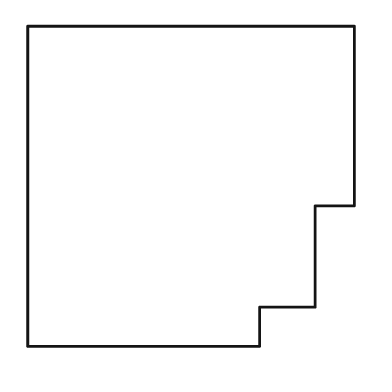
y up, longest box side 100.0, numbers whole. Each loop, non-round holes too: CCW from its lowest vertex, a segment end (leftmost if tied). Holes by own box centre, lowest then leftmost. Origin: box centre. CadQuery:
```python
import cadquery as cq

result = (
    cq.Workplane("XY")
    .moveTo(-50.0, -49.0)
    .lineTo(21.0, -49.0)
    .lineTo(21.0, -37.0)
    .lineTo(38.0, -37.0)
    .lineTo(38.0, -6.0)
    .lineTo(50.0, -6.0)
    .lineTo(50.0, 49.0)
    .lineTo(-50.0, 49.0)
    .close()
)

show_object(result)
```